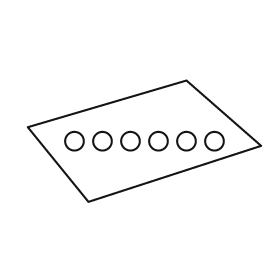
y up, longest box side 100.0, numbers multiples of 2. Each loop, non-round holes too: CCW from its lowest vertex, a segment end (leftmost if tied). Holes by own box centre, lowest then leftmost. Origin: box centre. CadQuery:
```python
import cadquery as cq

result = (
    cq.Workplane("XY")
    .moveTo(-24.0, -26.0)
    .lineTo(50.0, -2.0)
    .lineTo(18.0, 26.0)
    .lineTo(-50.0, 6.0)
    .close()
    .moveTo(-30.0, 0.0)
    .circle(4.0)
    .moveTo(-18.0, 0.0)
    .circle(4.0)
    .moveTo(-6.0, 0.0)
    .circle(4.0)
    .moveTo(6.0, 0.0)
    .circle(4.0)
    .moveTo(18.0, 0.0)
    .circle(4.0)
    .moveTo(30.0, 0.0)
    .circle(4.0)
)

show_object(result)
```